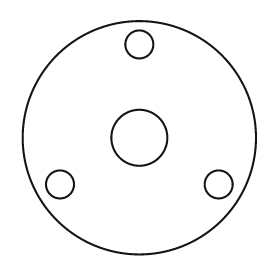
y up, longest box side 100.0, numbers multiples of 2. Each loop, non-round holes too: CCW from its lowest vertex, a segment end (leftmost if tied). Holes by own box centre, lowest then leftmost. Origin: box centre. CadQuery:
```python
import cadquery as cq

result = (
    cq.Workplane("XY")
    .moveTo(0.0, 0.0)
    .circle(50.0)
    .moveTo(-34.0, -20.0)
    .circle(6.0)
    .moveTo(34.0, -20.0)
    .circle(6.0)
    .moveTo(0.0, 0.0)
    .circle(12.0)
    .moveTo(0.0, 40.0)
    .circle(6.0)
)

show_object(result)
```